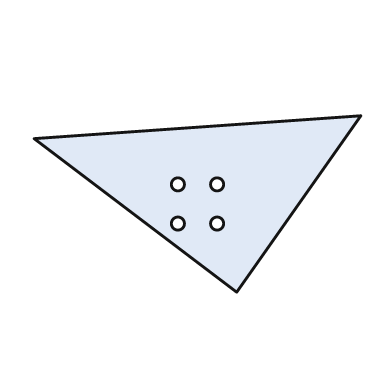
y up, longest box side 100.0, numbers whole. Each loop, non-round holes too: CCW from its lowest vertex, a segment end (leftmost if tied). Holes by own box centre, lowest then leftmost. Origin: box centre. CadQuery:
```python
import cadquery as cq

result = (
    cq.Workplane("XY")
    .moveTo(12.0, -27.0)
    .lineTo(50.0, 27.0)
    .lineTo(-50.0, 20.0)
    .close()
    .moveTo(-6.0, -6.0)
    .circle(2.0)
    .moveTo(6.0, -6.0)
    .circle(2.0)
    .moveTo(-6.0, 6.0)
    .circle(2.0)
    .moveTo(6.0, 6.0)
    .circle(2.0)
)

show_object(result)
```